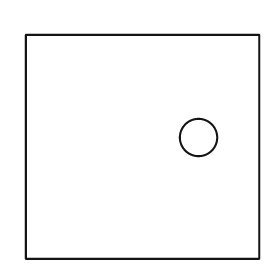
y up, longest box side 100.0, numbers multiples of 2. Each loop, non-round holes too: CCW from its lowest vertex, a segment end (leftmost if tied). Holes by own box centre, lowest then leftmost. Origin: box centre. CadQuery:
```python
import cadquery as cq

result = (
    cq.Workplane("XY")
    .moveTo(-50.0, -48.0)
    .lineTo(50.0, -48.0)
    .lineTo(50.0, 48.0)
    .lineTo(-50.0, 48.0)
    .close()
    .moveTo(24.0, 4.0)
    .circle(8.0)
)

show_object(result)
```